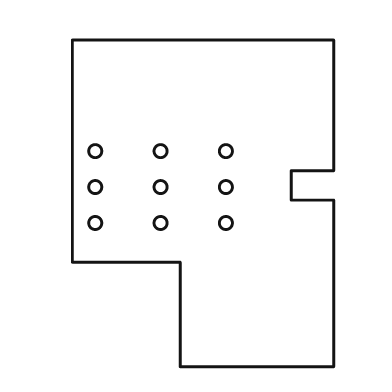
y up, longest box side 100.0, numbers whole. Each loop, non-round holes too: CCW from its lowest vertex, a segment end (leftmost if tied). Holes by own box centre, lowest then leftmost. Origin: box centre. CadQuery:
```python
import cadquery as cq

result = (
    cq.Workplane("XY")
    .moveTo(-7.0, -50.0)
    .lineTo(40.0, -50.0)
    .lineTo(40.0, 1.0)
    .lineTo(27.0, 1.0)
    .lineTo(27.0, 10.0)
    .lineTo(40.0, 10.0)
    .lineTo(40.0, 50.0)
    .lineTo(-40.0, 50.0)
    .lineTo(-40.0, -18.0)
    .lineTo(-7.0, -18.0)
    .close()
    .moveTo(-33.0, -6.0)
    .circle(2.0)
    .moveTo(-13.0, -6.0)
    .circle(2.0)
    .moveTo(7.0, -6.0)
    .circle(2.0)
    .moveTo(-33.0, 5.0)
    .circle(2.0)
    .moveTo(-13.0, 5.0)
    .circle(2.0)
    .moveTo(7.0, 5.0)
    .circle(2.0)
    .moveTo(-33.0, 16.0)
    .circle(2.0)
    .moveTo(-13.0, 16.0)
    .circle(2.0)
    .moveTo(7.0, 16.0)
    .circle(2.0)
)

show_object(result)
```